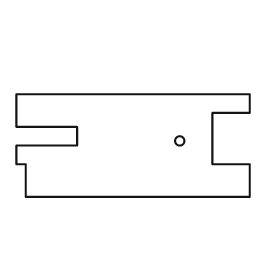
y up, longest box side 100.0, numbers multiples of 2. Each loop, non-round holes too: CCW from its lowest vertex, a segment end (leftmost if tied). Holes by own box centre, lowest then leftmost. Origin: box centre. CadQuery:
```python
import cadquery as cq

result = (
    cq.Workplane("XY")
    .moveTo(-46.0, -22.0)
    .lineTo(50.0, -22.0)
    .lineTo(50.0, -8.0)
    .lineTo(34.0, -8.0)
    .lineTo(34.0, 14.0)
    .lineTo(50.0, 14.0)
    .lineTo(50.0, 22.0)
    .lineTo(-50.0, 22.0)
    .lineTo(-50.0, 8.0)
    .lineTo(-24.0, 8.0)
    .lineTo(-24.0, 0.0)
    .lineTo(-50.0, 0.0)
    .lineTo(-50.0, -8.0)
    .lineTo(-46.0, -8.0)
    .close()
    .moveTo(20.0, 2.0)
    .circle(2.0)
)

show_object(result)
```